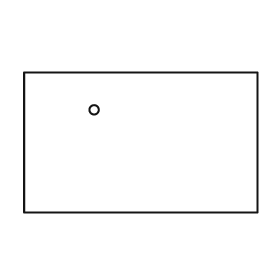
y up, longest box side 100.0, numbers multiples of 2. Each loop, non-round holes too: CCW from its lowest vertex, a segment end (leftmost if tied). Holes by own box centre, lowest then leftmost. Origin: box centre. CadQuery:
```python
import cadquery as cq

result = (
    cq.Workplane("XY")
    .moveTo(-50.0, -30.0)
    .lineTo(50.0, -30.0)
    .lineTo(50.0, 30.0)
    .lineTo(-50.0, 30.0)
    .close()
    .moveTo(-20.0, 14.0)
    .circle(2.0)
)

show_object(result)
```